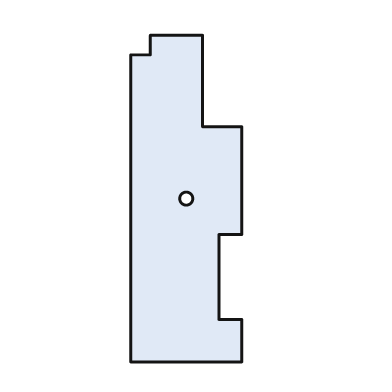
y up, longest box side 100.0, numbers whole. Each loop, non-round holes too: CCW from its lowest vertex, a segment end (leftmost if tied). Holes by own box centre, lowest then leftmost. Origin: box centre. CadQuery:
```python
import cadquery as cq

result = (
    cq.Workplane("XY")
    .moveTo(-17.0, -50.0)
    .lineTo(17.0, -50.0)
    .lineTo(17.0, -37.0)
    .lineTo(10.0, -37.0)
    .lineTo(10.0, -11.0)
    .lineTo(17.0, -11.0)
    .lineTo(17.0, 22.0)
    .lineTo(5.0, 22.0)
    .lineTo(5.0, 50.0)
    .lineTo(-11.0, 50.0)
    .lineTo(-11.0, 44.0)
    .lineTo(-17.0, 44.0)
    .close()
    .moveTo(0.0, 0.0)
    .circle(2.0)
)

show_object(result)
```